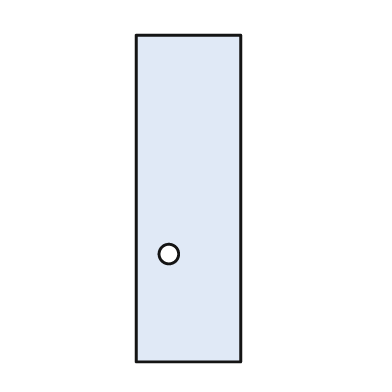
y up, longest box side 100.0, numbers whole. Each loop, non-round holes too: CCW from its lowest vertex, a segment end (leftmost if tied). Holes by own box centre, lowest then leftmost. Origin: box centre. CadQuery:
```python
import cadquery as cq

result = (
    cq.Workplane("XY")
    .moveTo(-16.0, -50.0)
    .lineTo(16.0, -50.0)
    .lineTo(16.0, 50.0)
    .lineTo(-16.0, 50.0)
    .close()
    .moveTo(-6.0, -17.0)
    .circle(3.0)
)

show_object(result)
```